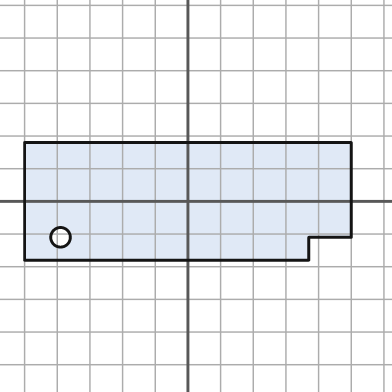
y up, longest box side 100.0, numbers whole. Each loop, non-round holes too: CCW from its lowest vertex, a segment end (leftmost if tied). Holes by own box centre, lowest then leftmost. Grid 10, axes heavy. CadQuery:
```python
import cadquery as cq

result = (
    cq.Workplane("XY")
    .moveTo(-50.0, -18.0)
    .lineTo(37.0, -18.0)
    .lineTo(37.0, -11.0)
    .lineTo(50.0, -11.0)
    .lineTo(50.0, 18.0)
    .lineTo(-50.0, 18.0)
    .close()
    .moveTo(-39.0, -11.0)
    .circle(3.0)
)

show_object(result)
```